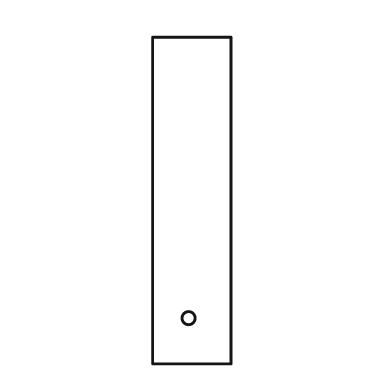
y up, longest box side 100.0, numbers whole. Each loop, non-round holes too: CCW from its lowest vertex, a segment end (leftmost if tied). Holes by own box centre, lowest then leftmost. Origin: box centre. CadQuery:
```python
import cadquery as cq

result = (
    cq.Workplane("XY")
    .moveTo(-12.0, -50.0)
    .lineTo(12.0, -50.0)
    .lineTo(12.0, 50.0)
    .lineTo(-12.0, 50.0)
    .close()
    .moveTo(-1.0, -36.0)
    .circle(2.0)
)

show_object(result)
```